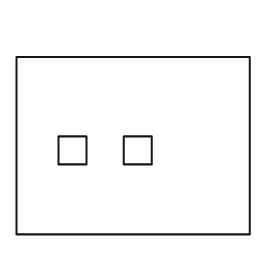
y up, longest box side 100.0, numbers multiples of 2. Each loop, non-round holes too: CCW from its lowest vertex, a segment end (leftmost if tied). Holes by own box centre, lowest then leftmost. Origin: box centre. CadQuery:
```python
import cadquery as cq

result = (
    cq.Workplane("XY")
    .moveTo(-50.0, -38.0)
    .lineTo(50.0, -38.0)
    .lineTo(50.0, 38.0)
    .lineTo(-50.0, 38.0)
    .close()
    .moveTo(-32.0, -8.0)
    .lineTo(-20.0, -8.0)
    .lineTo(-20.0, 4.0)
    .lineTo(-32.0, 4.0)
    .close()
    .moveTo(-4.0, -8.0)
    .lineTo(8.0, -8.0)
    .lineTo(8.0, 4.0)
    .lineTo(-4.0, 4.0)
    .close()
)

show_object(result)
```